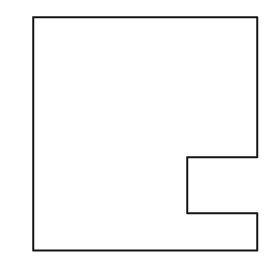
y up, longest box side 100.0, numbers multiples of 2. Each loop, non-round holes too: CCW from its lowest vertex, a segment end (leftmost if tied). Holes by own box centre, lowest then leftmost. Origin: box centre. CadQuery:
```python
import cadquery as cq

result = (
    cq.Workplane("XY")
    .moveTo(-48.0, -50.0)
    .lineTo(48.0, -50.0)
    .lineTo(48.0, -34.0)
    .lineTo(18.0, -34.0)
    .lineTo(18.0, -10.0)
    .lineTo(48.0, -10.0)
    .lineTo(48.0, 50.0)
    .lineTo(-48.0, 50.0)
    .close()
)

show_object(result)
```